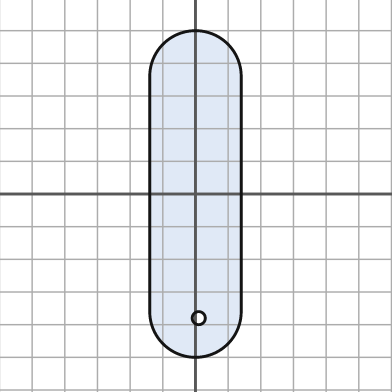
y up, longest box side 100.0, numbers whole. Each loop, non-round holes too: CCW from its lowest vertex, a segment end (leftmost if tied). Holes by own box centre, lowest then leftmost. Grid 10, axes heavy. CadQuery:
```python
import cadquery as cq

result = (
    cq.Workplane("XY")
    .moveTo(-14.0, -36.0)
    .threePointArc((0.0, -50.0), (14.0, -36.0))
    .lineTo(14.0, 36.0)
    .threePointArc((0.0, 50.0), (-14.0, 36.0))
    .close()
    .moveTo(1.0, -38.0)
    .circle(2.0)
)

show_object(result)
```